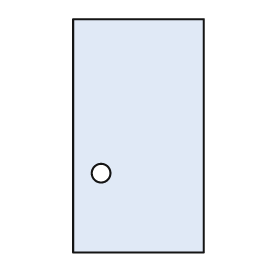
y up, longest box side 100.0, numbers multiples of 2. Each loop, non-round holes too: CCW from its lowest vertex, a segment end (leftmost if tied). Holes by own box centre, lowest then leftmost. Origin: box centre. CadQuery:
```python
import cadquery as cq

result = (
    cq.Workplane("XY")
    .moveTo(-28.0, -50.0)
    .lineTo(28.0, -50.0)
    .lineTo(28.0, 50.0)
    .lineTo(-28.0, 50.0)
    .close()
    .moveTo(-16.0, -16.0)
    .circle(4.0)
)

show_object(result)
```